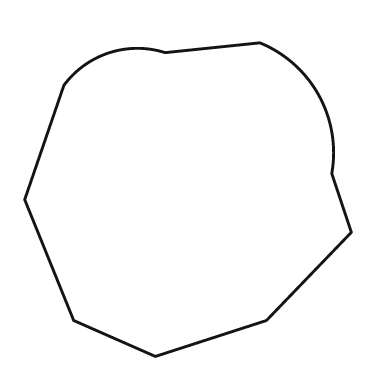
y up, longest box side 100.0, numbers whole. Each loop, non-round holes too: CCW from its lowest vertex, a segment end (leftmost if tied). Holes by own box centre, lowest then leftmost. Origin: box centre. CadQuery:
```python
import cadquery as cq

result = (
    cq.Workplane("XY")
    .moveTo(-10.0, -48.0)
    .lineTo(24.0, -37.0)
    .lineTo(50.0, -10.0)
    .lineTo(44.0, 8.0)
    .threePointArc((40.0, 32.0), (22.0, 48.0))
    .lineTo(-7.0, 45.0)
    .threePointArc((-24.0, 45.0), (-38.0, 35.0))
    .lineTo(-50.0, 0.0)
    .lineTo(-35.0, -37.0)
    .close()
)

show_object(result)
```